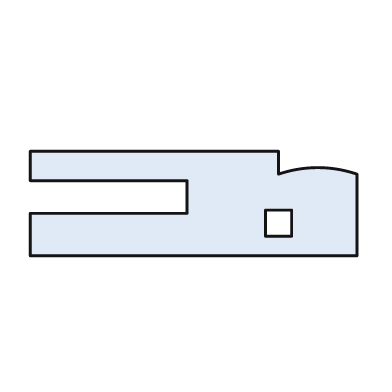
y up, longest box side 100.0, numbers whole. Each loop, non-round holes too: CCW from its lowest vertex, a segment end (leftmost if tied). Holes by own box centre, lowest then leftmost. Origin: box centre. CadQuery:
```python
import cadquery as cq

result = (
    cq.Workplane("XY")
    .moveTo(-50.0, -16.0)
    .lineTo(50.0, -16.0)
    .lineTo(50.0, 9.0)
    .threePointArc((38.0, 11.0), (26.0, 9.0))
    .lineTo(26.0, 16.0)
    .lineTo(-50.0, 16.0)
    .lineTo(-50.0, 7.0)
    .lineTo(-2.0, 7.0)
    .lineTo(-2.0, -3.0)
    .lineTo(-50.0, -3.0)
    .close()
    .moveTo(22.0, -10.0)
    .lineTo(30.0, -10.0)
    .lineTo(30.0, -2.0)
    .lineTo(22.0, -2.0)
    .close()
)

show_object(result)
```